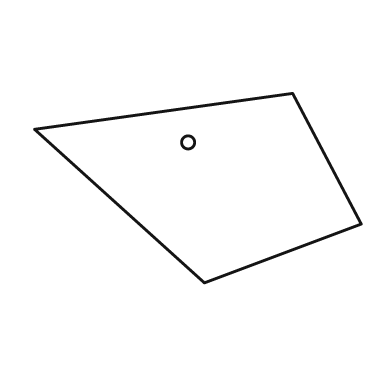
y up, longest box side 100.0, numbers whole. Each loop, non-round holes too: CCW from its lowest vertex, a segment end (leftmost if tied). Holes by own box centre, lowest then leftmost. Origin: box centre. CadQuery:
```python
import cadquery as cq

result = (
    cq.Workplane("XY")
    .moveTo(2.0, -29.0)
    .lineTo(50.0, -11.0)
    .lineTo(29.0, 29.0)
    .lineTo(-50.0, 18.0)
    .close()
    .moveTo(-3.0, 14.0)
    .circle(2.0)
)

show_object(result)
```